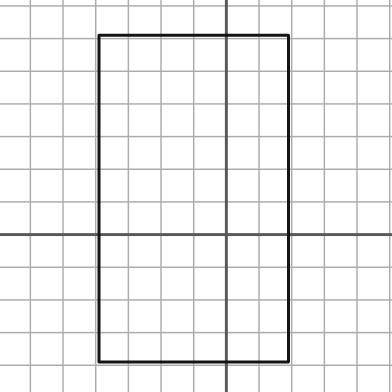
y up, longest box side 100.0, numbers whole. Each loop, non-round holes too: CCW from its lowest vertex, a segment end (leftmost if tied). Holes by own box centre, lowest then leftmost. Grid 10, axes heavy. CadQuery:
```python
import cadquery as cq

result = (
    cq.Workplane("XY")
    .moveTo(-39.0, -39.0)
    .lineTo(19.0, -39.0)
    .lineTo(19.0, 61.0)
    .lineTo(-39.0, 61.0)
    .close()
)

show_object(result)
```